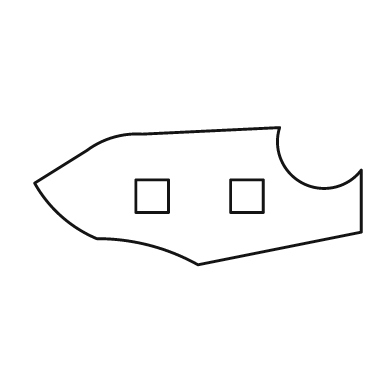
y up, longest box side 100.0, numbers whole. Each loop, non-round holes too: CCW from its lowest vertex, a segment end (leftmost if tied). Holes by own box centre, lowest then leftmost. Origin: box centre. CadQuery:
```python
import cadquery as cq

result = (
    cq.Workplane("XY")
    .moveTo(0.0, -21.0)
    .lineTo(50.0, -11.0)
    .lineTo(50.0, 8.0)
    .threePointArc((32.0, 4.0), (25.0, 21.0))
    .lineTo(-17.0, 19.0)
    .threePointArc((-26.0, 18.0), (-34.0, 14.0))
    .lineTo(-50.0, 4.0)
    .threePointArc((-42.0, -6.0), (-31.0, -13.0))
    .threePointArc((-15.0, -15.0), (0.0, -21.0))
    .close()
    .moveTo(-19.0, -5.0)
    .lineTo(-9.0, -5.0)
    .lineTo(-9.0, 5.0)
    .lineTo(-19.0, 5.0)
    .close()
    .moveTo(10.0, -5.0)
    .lineTo(20.0, -5.0)
    .lineTo(20.0, 5.0)
    .lineTo(10.0, 5.0)
    .close()
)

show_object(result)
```